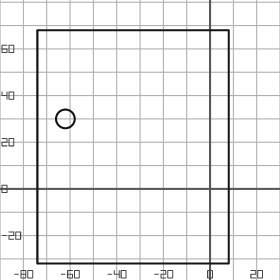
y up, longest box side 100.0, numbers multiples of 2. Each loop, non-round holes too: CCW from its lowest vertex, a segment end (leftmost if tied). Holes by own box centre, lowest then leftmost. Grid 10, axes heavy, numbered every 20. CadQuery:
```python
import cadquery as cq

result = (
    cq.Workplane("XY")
    .moveTo(-74.0, -32.0)
    .lineTo(8.0, -32.0)
    .lineTo(8.0, 68.0)
    .lineTo(-74.0, 68.0)
    .close()
    .moveTo(-62.0, 30.0)
    .circle(4.0)
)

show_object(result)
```